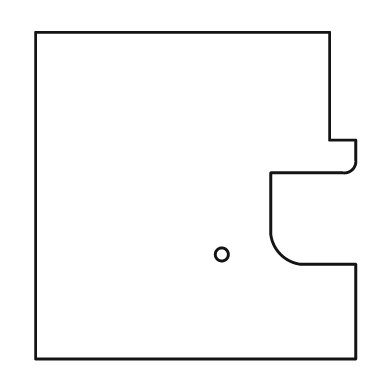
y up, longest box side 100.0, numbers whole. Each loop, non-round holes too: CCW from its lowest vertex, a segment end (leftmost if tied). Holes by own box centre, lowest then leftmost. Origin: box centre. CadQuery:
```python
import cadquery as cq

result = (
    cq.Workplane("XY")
    .moveTo(-49.0, -50.0)
    .lineTo(49.0, -50.0)
    .lineTo(49.0, -21.0)
    .lineTo(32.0, -21.0)
    .threePointArc((26.0, -18.0), (23.0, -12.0))
    .lineTo(23.0, 7.0)
    .lineTo(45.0, 7.0)
    .threePointArc((48.0, 8.0), (49.0, 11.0))
    .lineTo(49.0, 17.0)
    .lineTo(41.0, 17.0)
    .lineTo(41.0, 50.0)
    .lineTo(-49.0, 50.0)
    .close()
    .moveTo(8.0, -18.0)
    .circle(2.0)
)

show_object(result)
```